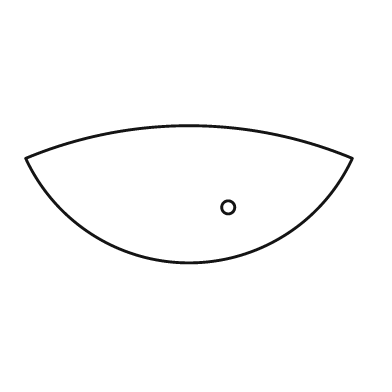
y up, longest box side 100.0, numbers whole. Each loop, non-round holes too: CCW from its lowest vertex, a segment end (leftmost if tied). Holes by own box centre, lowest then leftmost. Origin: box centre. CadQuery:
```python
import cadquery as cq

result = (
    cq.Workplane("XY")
    .moveTo(-50.0, 11.0)
    .threePointArc((0.0, -21.0), (50.0, 11.0))
    .threePointArc((0.0, 21.0), (-50.0, 11.0))
    .close()
    .moveTo(12.0, -4.0)
    .circle(2.0)
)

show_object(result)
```